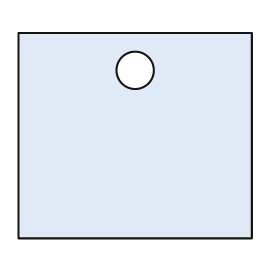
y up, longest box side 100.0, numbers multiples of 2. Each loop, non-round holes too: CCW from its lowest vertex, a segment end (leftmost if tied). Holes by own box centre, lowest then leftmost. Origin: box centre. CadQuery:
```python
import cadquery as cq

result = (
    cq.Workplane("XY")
    .moveTo(-50.0, -44.0)
    .lineTo(50.0, -44.0)
    .lineTo(50.0, 44.0)
    .lineTo(-50.0, 44.0)
    .close()
    .moveTo(0.0, 28.0)
    .circle(8.0)
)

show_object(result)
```